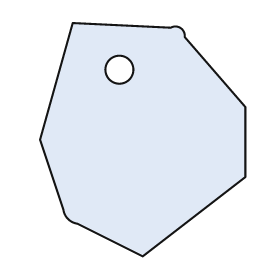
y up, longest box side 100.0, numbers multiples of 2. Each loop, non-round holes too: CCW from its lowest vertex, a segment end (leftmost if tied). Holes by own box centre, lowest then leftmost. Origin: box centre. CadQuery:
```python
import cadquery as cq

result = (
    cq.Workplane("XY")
    .moveTo(0.0, -50.0)
    .lineTo(44.0, -16.0)
    .lineTo(44.0, 14.0)
    .lineTo(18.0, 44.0)
    .threePointArc((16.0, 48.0), (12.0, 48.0))
    .lineTo(-30.0, 50.0)
    .lineTo(-44.0, 0.0)
    .lineTo(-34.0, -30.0)
    .threePointArc((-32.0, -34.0), (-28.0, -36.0))
    .close()
    .moveTo(-10.0, 30.0)
    .circle(6.0)
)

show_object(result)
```